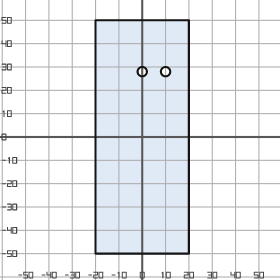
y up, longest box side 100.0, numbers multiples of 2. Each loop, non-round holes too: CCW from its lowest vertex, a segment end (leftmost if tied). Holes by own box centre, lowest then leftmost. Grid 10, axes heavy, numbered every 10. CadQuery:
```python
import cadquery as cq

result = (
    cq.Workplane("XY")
    .moveTo(-20.0, -50.0)
    .lineTo(20.0, -50.0)
    .lineTo(20.0, 50.0)
    .lineTo(-20.0, 50.0)
    .close()
    .moveTo(0.0, 28.0)
    .circle(2.0)
    .moveTo(10.0, 28.0)
    .circle(2.0)
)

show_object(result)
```